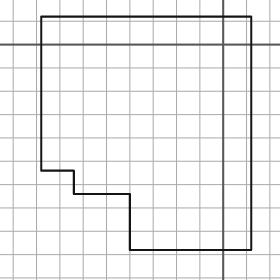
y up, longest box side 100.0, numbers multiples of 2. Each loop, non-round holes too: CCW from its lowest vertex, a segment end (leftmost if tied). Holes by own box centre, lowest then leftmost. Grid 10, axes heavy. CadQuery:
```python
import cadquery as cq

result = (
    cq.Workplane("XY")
    .moveTo(-40.0, -88.0)
    .lineTo(12.0, -88.0)
    .lineTo(12.0, 12.0)
    .lineTo(-78.0, 12.0)
    .lineTo(-78.0, -54.0)
    .lineTo(-64.0, -54.0)
    .lineTo(-64.0, -64.0)
    .lineTo(-40.0, -64.0)
    .close()
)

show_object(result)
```